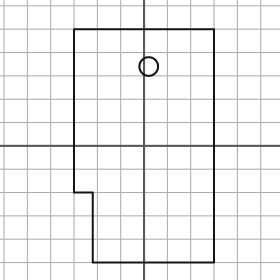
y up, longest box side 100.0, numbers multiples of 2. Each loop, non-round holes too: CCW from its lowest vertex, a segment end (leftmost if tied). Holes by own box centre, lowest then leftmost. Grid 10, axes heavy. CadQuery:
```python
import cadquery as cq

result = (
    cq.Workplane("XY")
    .moveTo(-22.0, -50.0)
    .lineTo(30.0, -50.0)
    .lineTo(30.0, 50.0)
    .lineTo(-30.0, 50.0)
    .lineTo(-30.0, -20.0)
    .lineTo(-22.0, -20.0)
    .close()
    .moveTo(2.0, 34.0)
    .circle(4.0)
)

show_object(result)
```